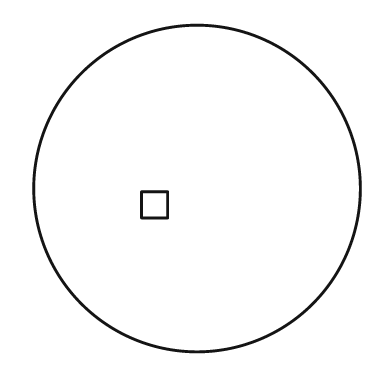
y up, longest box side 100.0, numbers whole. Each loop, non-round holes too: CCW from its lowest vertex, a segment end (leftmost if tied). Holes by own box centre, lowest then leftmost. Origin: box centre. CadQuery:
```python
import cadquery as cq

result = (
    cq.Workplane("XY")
    .moveTo(0.0, 0.0)
    .circle(50.0)
    .moveTo(-17.0, -9.0)
    .lineTo(-9.0, -9.0)
    .lineTo(-9.0, -1.0)
    .lineTo(-17.0, -1.0)
    .close()
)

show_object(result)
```